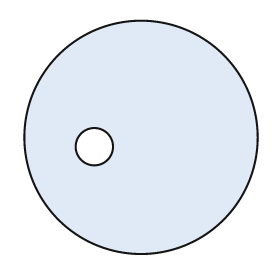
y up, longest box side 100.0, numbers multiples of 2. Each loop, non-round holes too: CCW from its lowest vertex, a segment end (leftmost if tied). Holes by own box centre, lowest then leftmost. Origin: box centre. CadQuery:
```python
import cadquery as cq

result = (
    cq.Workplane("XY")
    .moveTo(0.0, 0.0)
    .circle(50.0)
    .moveTo(-20.0, -4.0)
    .circle(8.0)
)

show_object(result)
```